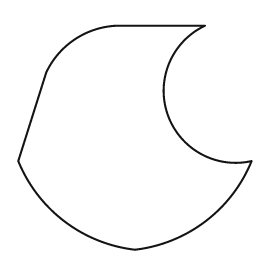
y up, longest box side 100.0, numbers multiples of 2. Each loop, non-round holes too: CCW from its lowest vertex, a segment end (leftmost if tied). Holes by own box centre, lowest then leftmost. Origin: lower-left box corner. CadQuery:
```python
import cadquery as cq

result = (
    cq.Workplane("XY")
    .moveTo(50.0, 0.0)
    .threePointArc((80.0, 12.0), (100.0, 38.0))
    .threePointArc((64.0, 58.0), (80.0, 96.0))
    .lineTo(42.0, 96.0)
    .threePointArc((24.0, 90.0), (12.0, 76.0))
    .lineTo(0.0, 38.0)
    .threePointArc((20.0, 12.0), (50.0, 0.0))
    .close()
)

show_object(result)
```